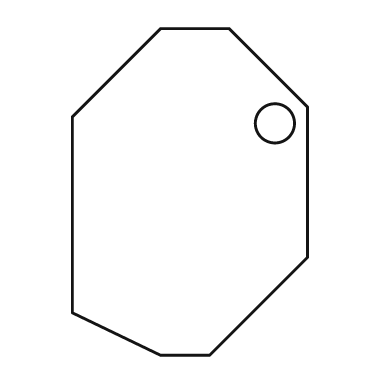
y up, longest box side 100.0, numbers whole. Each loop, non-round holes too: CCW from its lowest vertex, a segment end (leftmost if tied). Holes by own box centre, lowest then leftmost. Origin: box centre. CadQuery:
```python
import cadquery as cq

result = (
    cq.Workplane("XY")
    .moveTo(-9.0, -50.0)
    .lineTo(6.0, -50.0)
    .lineTo(36.0, -20.0)
    .lineTo(36.0, 26.0)
    .lineTo(12.0, 50.0)
    .lineTo(-9.0, 50.0)
    .lineTo(-36.0, 23.0)
    .lineTo(-36.0, -37.0)
    .close()
    .moveTo(26.0, 21.0)
    .circle(6.0)
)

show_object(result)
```